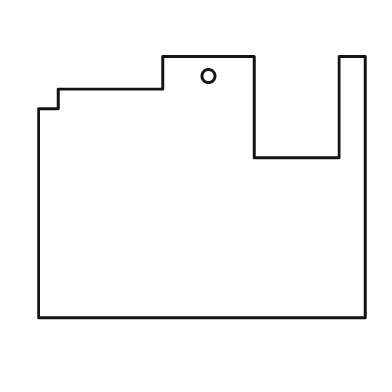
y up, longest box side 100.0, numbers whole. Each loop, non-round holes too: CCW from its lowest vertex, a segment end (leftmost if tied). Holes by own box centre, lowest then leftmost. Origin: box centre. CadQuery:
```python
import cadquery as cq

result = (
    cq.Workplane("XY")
    .moveTo(-50.0, -40.0)
    .lineTo(50.0, -40.0)
    .lineTo(50.0, 40.0)
    .lineTo(42.0, 40.0)
    .lineTo(42.0, 9.0)
    .lineTo(16.0, 9.0)
    .lineTo(16.0, 40.0)
    .lineTo(-12.0, 40.0)
    .lineTo(-12.0, 30.0)
    .lineTo(-44.0, 30.0)
    .lineTo(-44.0, 24.0)
    .lineTo(-50.0, 24.0)
    .close()
    .moveTo(2.0, 34.0)
    .circle(2.0)
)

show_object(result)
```